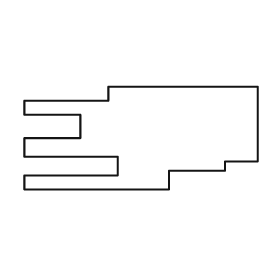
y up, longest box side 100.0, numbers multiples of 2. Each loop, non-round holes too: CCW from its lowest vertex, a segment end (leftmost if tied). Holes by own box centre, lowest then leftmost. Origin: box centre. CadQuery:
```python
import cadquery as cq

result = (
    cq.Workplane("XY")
    .moveTo(-50.0, -22.0)
    .lineTo(12.0, -22.0)
    .lineTo(12.0, -14.0)
    .lineTo(36.0, -14.0)
    .lineTo(36.0, -10.0)
    .lineTo(50.0, -10.0)
    .lineTo(50.0, 22.0)
    .lineTo(-14.0, 22.0)
    .lineTo(-14.0, 16.0)
    .lineTo(-50.0, 16.0)
    .lineTo(-50.0, 10.0)
    .lineTo(-26.0, 10.0)
    .lineTo(-26.0, 0.0)
    .lineTo(-50.0, 0.0)
    .lineTo(-50.0, -8.0)
    .lineTo(-10.0, -8.0)
    .lineTo(-10.0, -16.0)
    .lineTo(-50.0, -16.0)
    .close()
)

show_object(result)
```